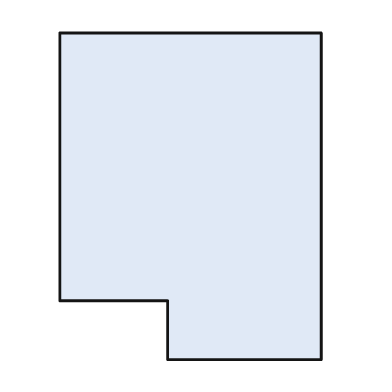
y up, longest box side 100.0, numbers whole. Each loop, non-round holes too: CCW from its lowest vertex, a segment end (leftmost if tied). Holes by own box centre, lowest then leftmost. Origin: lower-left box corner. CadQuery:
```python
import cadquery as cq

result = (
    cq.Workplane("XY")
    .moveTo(33.0, 0.0)
    .lineTo(80.0, 0.0)
    .lineTo(80.0, 100.0)
    .lineTo(0.0, 100.0)
    .lineTo(0.0, 18.0)
    .lineTo(33.0, 18.0)
    .close()
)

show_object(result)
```